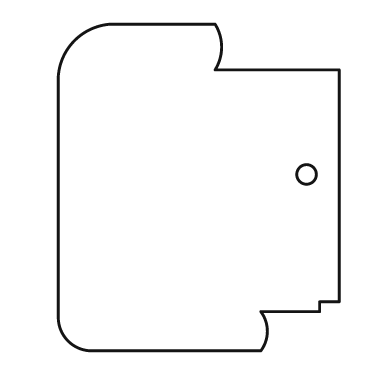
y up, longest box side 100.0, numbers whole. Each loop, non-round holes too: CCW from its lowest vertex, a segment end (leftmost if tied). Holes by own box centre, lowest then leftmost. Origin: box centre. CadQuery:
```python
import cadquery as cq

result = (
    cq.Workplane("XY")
    .moveTo(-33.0, -50.0)
    .lineTo(19.0, -50.0)
    .threePointArc((21.0, -44.0), (19.0, -38.0))
    .lineTo(37.0, -38.0)
    .lineTo(37.0, -35.0)
    .lineTo(43.0, -35.0)
    .lineTo(43.0, 36.0)
    .lineTo(5.0, 36.0)
    .threePointArc((7.0, 43.0), (5.0, 50.0))
    .lineTo(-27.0, 50.0)
    .threePointArc((-38.0, 45.0), (-43.0, 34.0))
    .lineTo(-43.0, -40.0)
    .threePointArc((-40.0, -47.0), (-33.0, -50.0))
    .close()
    .moveTo(33.0, 4.0)
    .circle(3.0)
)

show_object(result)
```